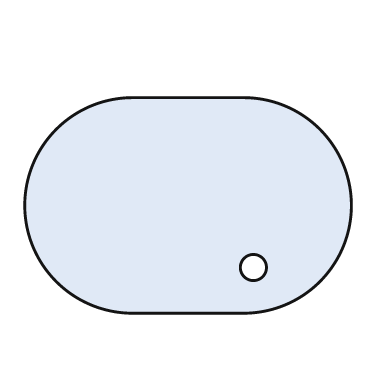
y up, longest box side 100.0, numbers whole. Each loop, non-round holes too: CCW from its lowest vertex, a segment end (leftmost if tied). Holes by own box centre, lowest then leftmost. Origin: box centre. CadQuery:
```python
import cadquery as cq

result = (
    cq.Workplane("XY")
    .moveTo(-17.0, -33.0)
    .lineTo(17.0, -33.0)
    .threePointArc((50.0, 0.0), (17.0, 33.0))
    .lineTo(-17.0, 33.0)
    .threePointArc((-50.0, 0.0), (-17.0, -33.0))
    .close()
    .moveTo(20.0, -19.0)
    .circle(4.0)
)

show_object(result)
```